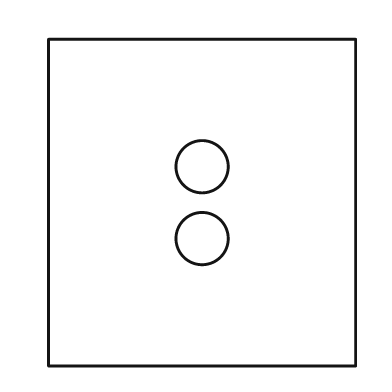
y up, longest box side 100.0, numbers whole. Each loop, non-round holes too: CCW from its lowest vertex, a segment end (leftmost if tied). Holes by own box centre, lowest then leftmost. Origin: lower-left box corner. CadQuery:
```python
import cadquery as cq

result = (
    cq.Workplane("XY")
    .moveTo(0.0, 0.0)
    .lineTo(94.0, 0.0)
    .lineTo(94.0, 100.0)
    .lineTo(0.0, 100.0)
    .close()
    .moveTo(47.0, 39.0)
    .circle(8.0)
    .moveTo(47.0, 61.0)
    .circle(8.0)
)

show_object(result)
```